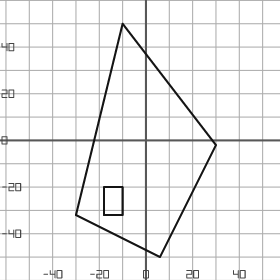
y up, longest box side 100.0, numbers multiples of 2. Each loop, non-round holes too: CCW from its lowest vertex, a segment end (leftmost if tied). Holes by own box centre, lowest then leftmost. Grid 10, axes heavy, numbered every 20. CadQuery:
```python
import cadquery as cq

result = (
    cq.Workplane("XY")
    .moveTo(6.0, -50.0)
    .lineTo(30.0, -2.0)
    .lineTo(-10.0, 50.0)
    .lineTo(-30.0, -32.0)
    .close()
    .moveTo(-18.0, -32.0)
    .lineTo(-10.0, -32.0)
    .lineTo(-10.0, -20.0)
    .lineTo(-18.0, -20.0)
    .close()
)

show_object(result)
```